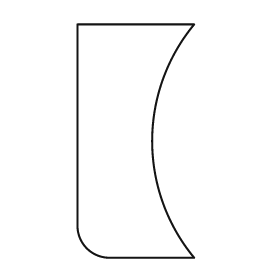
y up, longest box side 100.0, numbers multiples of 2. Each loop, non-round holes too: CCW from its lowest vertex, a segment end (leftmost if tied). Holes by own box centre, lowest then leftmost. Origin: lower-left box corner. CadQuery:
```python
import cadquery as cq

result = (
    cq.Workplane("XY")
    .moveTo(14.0, 0.0)
    .lineTo(50.0, 0.0)
    .threePointArc((32.0, 50.0), (50.0, 100.0))
    .lineTo(0.0, 100.0)
    .lineTo(0.0, 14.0)
    .threePointArc((4.0, 4.0), (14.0, 0.0))
    .close()
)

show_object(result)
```